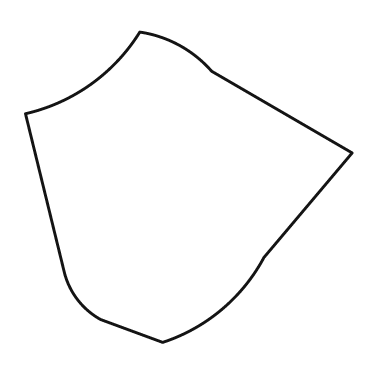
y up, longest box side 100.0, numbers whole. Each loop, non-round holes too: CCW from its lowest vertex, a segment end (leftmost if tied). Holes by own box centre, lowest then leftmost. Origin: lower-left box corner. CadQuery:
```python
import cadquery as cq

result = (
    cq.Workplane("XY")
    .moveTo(42.0, 0.0)
    .threePointArc((60.0, 10.0), (73.0, 26.0))
    .lineTo(100.0, 58.0)
    .lineTo(57.0, 83.0)
    .threePointArc((47.0, 91.0), (35.0, 95.0))
    .threePointArc((20.0, 79.0), (0.0, 70.0))
    .lineTo(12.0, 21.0)
    .threePointArc((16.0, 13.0), (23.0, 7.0))
    .close()
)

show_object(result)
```